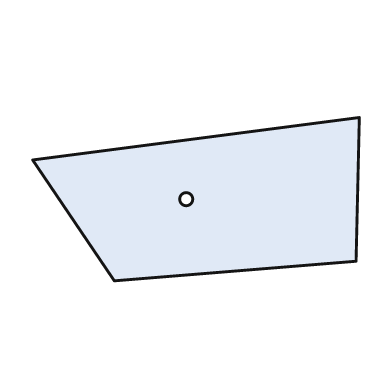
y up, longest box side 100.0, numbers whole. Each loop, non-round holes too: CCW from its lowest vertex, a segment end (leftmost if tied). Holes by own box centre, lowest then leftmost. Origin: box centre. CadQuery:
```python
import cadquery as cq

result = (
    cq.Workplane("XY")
    .moveTo(-25.0, -25.0)
    .lineTo(49.0, -19.0)
    .lineTo(50.0, 25.0)
    .lineTo(-50.0, 12.0)
    .close()
    .moveTo(-3.0, 0.0)
    .circle(2.0)
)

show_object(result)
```